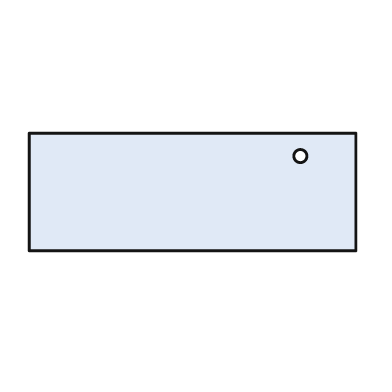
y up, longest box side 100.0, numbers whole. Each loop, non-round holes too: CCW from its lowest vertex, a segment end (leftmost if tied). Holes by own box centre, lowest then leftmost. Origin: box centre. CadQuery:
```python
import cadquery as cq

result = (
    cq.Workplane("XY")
    .moveTo(-50.0, -18.0)
    .lineTo(50.0, -18.0)
    .lineTo(50.0, 18.0)
    .lineTo(-50.0, 18.0)
    .close()
    .moveTo(33.0, 11.0)
    .circle(2.0)
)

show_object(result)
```